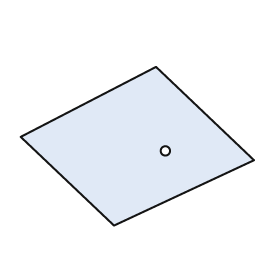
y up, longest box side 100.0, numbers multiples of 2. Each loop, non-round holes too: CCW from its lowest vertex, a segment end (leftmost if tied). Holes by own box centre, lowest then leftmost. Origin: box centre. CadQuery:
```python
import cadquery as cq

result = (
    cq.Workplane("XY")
    .moveTo(-10.0, -34.0)
    .lineTo(50.0, -6.0)
    .lineTo(8.0, 34.0)
    .lineTo(-50.0, 4.0)
    .close()
    .moveTo(12.0, -2.0)
    .circle(2.0)
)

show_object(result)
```